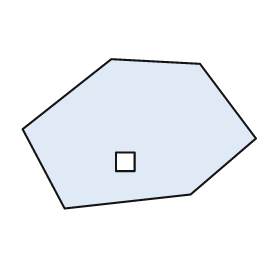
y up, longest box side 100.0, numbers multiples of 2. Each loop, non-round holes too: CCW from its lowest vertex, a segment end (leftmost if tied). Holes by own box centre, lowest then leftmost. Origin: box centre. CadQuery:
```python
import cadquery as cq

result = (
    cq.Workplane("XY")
    .moveTo(-32.0, -32.0)
    .lineTo(22.0, -26.0)
    .lineTo(50.0, -2.0)
    .lineTo(26.0, 30.0)
    .lineTo(-12.0, 32.0)
    .lineTo(-50.0, 2.0)
    .close()
    .moveTo(-10.0, -16.0)
    .lineTo(-2.0, -16.0)
    .lineTo(-2.0, -8.0)
    .lineTo(-10.0, -8.0)
    .close()
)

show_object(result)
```